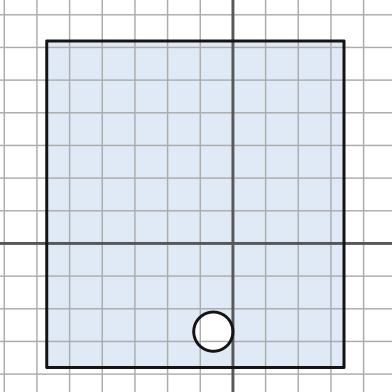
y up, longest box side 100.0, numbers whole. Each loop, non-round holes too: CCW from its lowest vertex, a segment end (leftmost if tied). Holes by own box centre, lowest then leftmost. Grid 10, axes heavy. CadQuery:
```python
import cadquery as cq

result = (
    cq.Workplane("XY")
    .moveTo(-57.0, -38.0)
    .lineTo(34.0, -38.0)
    .lineTo(34.0, 62.0)
    .lineTo(-57.0, 62.0)
    .close()
    .moveTo(-6.0, -27.0)
    .circle(6.0)
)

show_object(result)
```